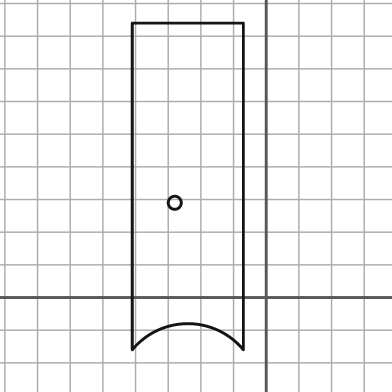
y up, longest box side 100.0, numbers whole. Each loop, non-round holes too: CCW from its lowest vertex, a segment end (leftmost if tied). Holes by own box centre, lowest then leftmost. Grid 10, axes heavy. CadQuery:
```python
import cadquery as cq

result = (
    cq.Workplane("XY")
    .moveTo(-41.0, -16.0)
    .threePointArc((-24.0, -8.0), (-7.0, -16.0))
    .lineTo(-7.0, 84.0)
    .lineTo(-41.0, 84.0)
    .close()
    .moveTo(-28.0, 29.0)
    .circle(2.0)
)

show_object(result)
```